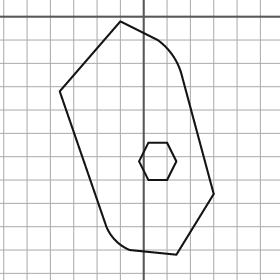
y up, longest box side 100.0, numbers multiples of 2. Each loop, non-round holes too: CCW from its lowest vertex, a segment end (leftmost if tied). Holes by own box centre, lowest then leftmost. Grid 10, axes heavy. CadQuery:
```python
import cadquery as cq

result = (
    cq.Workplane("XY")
    .moveTo(14.0, -102.0)
    .lineTo(30.0, -76.0)
    .lineTo(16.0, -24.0)
    .threePointArc((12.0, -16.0), (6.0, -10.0))
    .lineTo(-10.0, -2.0)
    .lineTo(-36.0, -32.0)
    .lineTo(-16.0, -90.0)
    .threePointArc((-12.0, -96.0), (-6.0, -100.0))
    .close()
    .moveTo(2.0, -70.0)
    .lineTo(10.0, -70.0)
    .lineTo(14.0, -62.0)
    .lineTo(10.0, -54.0)
    .lineTo(2.0, -54.0)
    .lineTo(-2.0, -62.0)
    .close()
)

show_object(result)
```